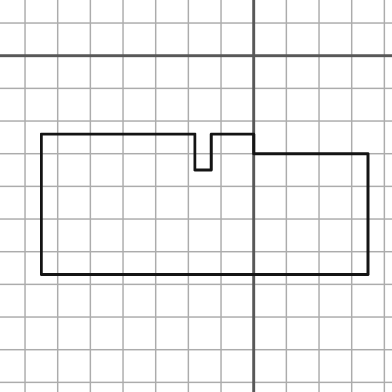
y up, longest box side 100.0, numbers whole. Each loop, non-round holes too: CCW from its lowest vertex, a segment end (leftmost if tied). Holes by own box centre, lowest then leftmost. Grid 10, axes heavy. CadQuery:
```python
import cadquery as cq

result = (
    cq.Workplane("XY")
    .moveTo(-65.0, -67.0)
    .lineTo(35.0, -67.0)
    .lineTo(35.0, -30.0)
    .lineTo(0.0, -30.0)
    .lineTo(0.0, -24.0)
    .lineTo(-13.0, -24.0)
    .lineTo(-13.0, -35.0)
    .lineTo(-18.0, -35.0)
    .lineTo(-18.0, -24.0)
    .lineTo(-65.0, -24.0)
    .close()
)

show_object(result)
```